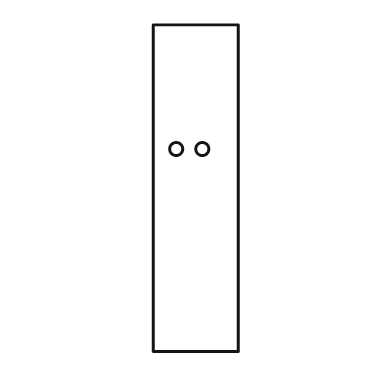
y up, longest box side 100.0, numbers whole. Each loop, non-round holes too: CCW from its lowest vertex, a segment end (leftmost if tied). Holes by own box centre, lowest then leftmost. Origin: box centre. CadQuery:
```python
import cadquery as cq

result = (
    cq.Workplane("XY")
    .moveTo(-13.0, -50.0)
    .lineTo(13.0, -50.0)
    .lineTo(13.0, 50.0)
    .lineTo(-13.0, 50.0)
    .close()
    .moveTo(-6.0, 12.0)
    .circle(2.0)
    .moveTo(2.0, 12.0)
    .circle(2.0)
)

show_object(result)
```